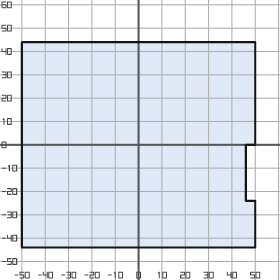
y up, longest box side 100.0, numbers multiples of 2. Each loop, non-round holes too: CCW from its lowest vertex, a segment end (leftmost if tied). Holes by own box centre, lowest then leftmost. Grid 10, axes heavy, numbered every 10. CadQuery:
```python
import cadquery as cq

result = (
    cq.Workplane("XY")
    .moveTo(-50.0, -44.0)
    .lineTo(50.0, -44.0)
    .lineTo(50.0, -24.0)
    .lineTo(46.0, -24.0)
    .lineTo(46.0, 0.0)
    .lineTo(50.0, 0.0)
    .lineTo(50.0, 44.0)
    .lineTo(-50.0, 44.0)
    .close()
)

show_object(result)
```